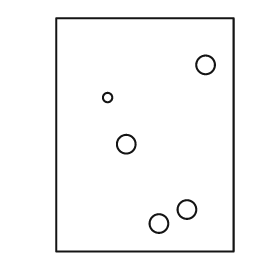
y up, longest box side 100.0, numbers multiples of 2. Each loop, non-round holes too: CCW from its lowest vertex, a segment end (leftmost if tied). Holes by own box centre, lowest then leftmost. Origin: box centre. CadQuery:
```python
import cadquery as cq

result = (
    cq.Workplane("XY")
    .moveTo(-38.0, -50.0)
    .lineTo(38.0, -50.0)
    .lineTo(38.0, 50.0)
    .lineTo(-38.0, 50.0)
    .close()
    .moveTo(6.0, -38.0)
    .circle(4.0)
    .moveTo(18.0, -32.0)
    .circle(4.0)
    .moveTo(-8.0, -4.0)
    .circle(4.0)
    .moveTo(-16.0, 16.0)
    .circle(2.0)
    .moveTo(26.0, 30.0)
    .circle(4.0)
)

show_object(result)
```